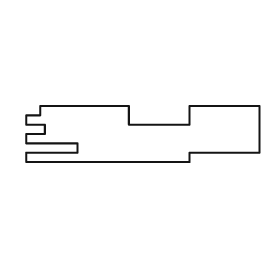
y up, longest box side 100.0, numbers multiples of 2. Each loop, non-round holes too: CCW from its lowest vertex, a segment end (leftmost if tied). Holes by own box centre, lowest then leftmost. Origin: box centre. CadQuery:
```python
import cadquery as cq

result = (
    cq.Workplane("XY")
    .moveTo(-50.0, -12.0)
    .lineTo(20.0, -12.0)
    .lineTo(20.0, -8.0)
    .lineTo(50.0, -8.0)
    .lineTo(50.0, 12.0)
    .lineTo(20.0, 12.0)
    .lineTo(20.0, 4.0)
    .lineTo(-6.0, 4.0)
    .lineTo(-6.0, 12.0)
    .lineTo(-44.0, 12.0)
    .lineTo(-44.0, 8.0)
    .lineTo(-50.0, 8.0)
    .lineTo(-50.0, 4.0)
    .lineTo(-42.0, 4.0)
    .lineTo(-42.0, 0.0)
    .lineTo(-50.0, 0.0)
    .lineTo(-50.0, -4.0)
    .lineTo(-28.0, -4.0)
    .lineTo(-28.0, -8.0)
    .lineTo(-50.0, -8.0)
    .close()
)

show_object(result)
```